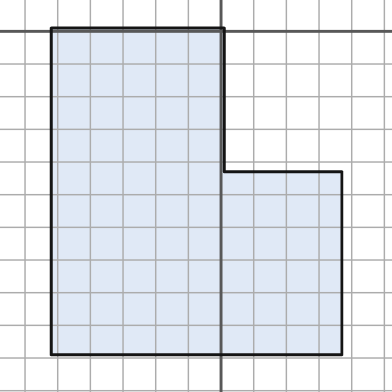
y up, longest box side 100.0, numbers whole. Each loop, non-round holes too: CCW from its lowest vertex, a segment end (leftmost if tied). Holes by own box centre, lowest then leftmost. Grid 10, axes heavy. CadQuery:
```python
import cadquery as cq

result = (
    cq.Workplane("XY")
    .moveTo(-52.0, -99.0)
    .lineTo(37.0, -99.0)
    .lineTo(37.0, -43.0)
    .lineTo(1.0, -43.0)
    .lineTo(1.0, 1.0)
    .lineTo(-52.0, 1.0)
    .close()
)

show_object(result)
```